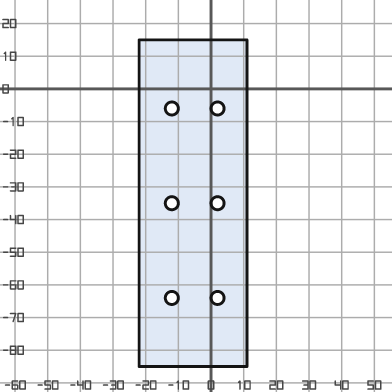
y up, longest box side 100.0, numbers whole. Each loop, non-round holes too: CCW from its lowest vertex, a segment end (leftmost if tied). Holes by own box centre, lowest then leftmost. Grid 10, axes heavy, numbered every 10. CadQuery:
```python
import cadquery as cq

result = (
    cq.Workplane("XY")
    .moveTo(-22.0, -85.0)
    .lineTo(11.0, -85.0)
    .lineTo(11.0, 15.0)
    .lineTo(-22.0, 15.0)
    .close()
    .moveTo(-12.0, -64.0)
    .circle(2.0)
    .moveTo(2.0, -64.0)
    .circle(2.0)
    .moveTo(-12.0, -35.0)
    .circle(2.0)
    .moveTo(2.0, -35.0)
    .circle(2.0)
    .moveTo(-12.0, -6.0)
    .circle(2.0)
    .moveTo(2.0, -6.0)
    .circle(2.0)
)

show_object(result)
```